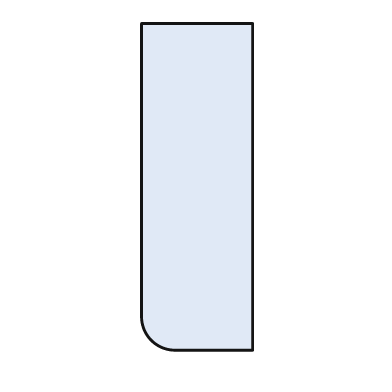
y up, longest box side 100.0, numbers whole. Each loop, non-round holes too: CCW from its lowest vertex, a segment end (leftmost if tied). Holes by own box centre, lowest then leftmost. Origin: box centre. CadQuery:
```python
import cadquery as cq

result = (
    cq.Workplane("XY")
    .moveTo(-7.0, -50.0)
    .lineTo(17.0, -50.0)
    .lineTo(17.0, 50.0)
    .lineTo(-17.0, 50.0)
    .lineTo(-17.0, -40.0)
    .threePointArc((-14.0, -47.0), (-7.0, -50.0))
    .close()
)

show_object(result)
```